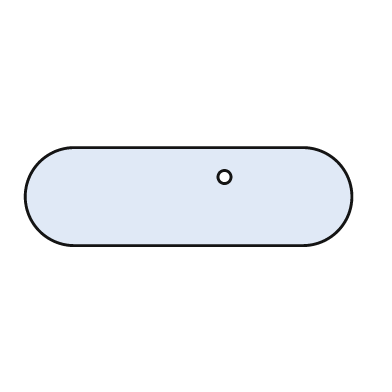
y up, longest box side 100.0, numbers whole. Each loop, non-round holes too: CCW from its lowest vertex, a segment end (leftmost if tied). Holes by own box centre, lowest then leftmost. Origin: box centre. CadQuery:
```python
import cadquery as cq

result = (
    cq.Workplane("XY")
    .moveTo(-35.0, -15.0)
    .lineTo(35.0, -15.0)
    .threePointArc((50.0, 0.0), (35.0, 15.0))
    .lineTo(-35.0, 15.0)
    .threePointArc((-50.0, 0.0), (-35.0, -15.0))
    .close()
    .moveTo(11.0, 6.0)
    .circle(2.0)
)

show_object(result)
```